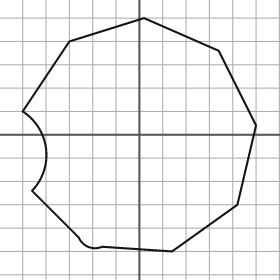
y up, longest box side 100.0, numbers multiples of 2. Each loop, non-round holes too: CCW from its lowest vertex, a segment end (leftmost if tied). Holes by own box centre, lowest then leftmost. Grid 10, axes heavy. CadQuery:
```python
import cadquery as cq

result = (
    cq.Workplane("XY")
    .moveTo(14.0, -50.0)
    .lineTo(42.0, -30.0)
    .lineTo(50.0, 4.0)
    .lineTo(34.0, 36.0)
    .lineTo(2.0, 50.0)
    .lineTo(-30.0, 40.0)
    .lineTo(-50.0, 10.0)
    .threePointArc((-40.0, -6.0), (-46.0, -24.0))
    .lineTo(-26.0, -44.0)
    .threePointArc((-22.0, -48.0), (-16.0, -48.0))
    .close()
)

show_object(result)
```